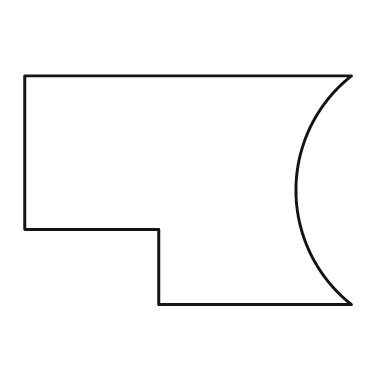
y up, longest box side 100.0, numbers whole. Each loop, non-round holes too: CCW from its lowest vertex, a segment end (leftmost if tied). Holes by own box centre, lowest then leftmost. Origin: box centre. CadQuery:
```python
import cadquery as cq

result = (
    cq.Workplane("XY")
    .moveTo(-9.0, -35.0)
    .lineTo(50.0, -35.0)
    .threePointArc((33.0, 0.0), (50.0, 35.0))
    .lineTo(-50.0, 35.0)
    .lineTo(-50.0, -12.0)
    .lineTo(-9.0, -12.0)
    .close()
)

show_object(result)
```